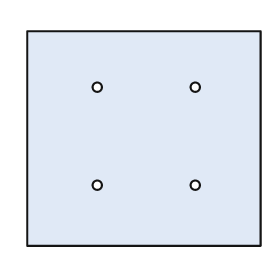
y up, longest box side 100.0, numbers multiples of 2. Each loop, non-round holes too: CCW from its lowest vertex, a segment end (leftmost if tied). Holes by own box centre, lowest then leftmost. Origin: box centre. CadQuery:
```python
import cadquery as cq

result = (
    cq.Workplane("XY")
    .moveTo(-50.0, -46.0)
    .lineTo(50.0, -46.0)
    .lineTo(50.0, 46.0)
    .lineTo(-50.0, 46.0)
    .close()
    .moveTo(-20.0, -20.0)
    .circle(2.0)
    .moveTo(22.0, -20.0)
    .circle(2.0)
    .moveTo(-20.0, 22.0)
    .circle(2.0)
    .moveTo(22.0, 22.0)
    .circle(2.0)
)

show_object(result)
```